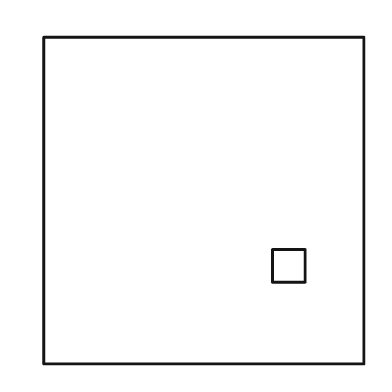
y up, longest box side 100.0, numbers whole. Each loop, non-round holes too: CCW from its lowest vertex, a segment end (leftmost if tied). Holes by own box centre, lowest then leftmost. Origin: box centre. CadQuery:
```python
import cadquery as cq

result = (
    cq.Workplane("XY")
    .moveTo(-49.0, -50.0)
    .lineTo(49.0, -50.0)
    .lineTo(49.0, 50.0)
    .lineTo(-49.0, 50.0)
    .close()
    .moveTo(21.0, -25.0)
    .lineTo(31.0, -25.0)
    .lineTo(31.0, -15.0)
    .lineTo(21.0, -15.0)
    .close()
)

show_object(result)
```